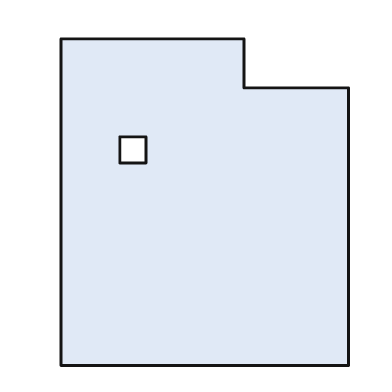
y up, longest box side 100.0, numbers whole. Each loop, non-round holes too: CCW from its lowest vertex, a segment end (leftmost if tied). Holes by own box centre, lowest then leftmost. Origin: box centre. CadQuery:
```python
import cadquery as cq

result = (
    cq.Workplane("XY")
    .moveTo(-44.0, -50.0)
    .lineTo(44.0, -50.0)
    .lineTo(44.0, 35.0)
    .lineTo(12.0, 35.0)
    .lineTo(12.0, 50.0)
    .lineTo(-44.0, 50.0)
    .close()
    .moveTo(-26.0, 12.0)
    .lineTo(-18.0, 12.0)
    .lineTo(-18.0, 20.0)
    .lineTo(-26.0, 20.0)
    .close()
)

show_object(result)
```